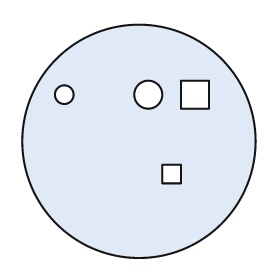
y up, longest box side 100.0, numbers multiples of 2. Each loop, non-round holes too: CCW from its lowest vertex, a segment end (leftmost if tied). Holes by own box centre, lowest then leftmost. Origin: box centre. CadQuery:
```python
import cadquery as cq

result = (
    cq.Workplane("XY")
    .moveTo(0.0, 0.0)
    .circle(50.0)
    .moveTo(10.0, -18.0)
    .lineTo(18.0, -18.0)
    .lineTo(18.0, -10.0)
    .lineTo(10.0, -10.0)
    .close()
    .moveTo(-32.0, 20.0)
    .circle(4.0)
    .moveTo(4.0, 20.0)
    .circle(6.0)
    .moveTo(18.0, 14.0)
    .lineTo(30.0, 14.0)
    .lineTo(30.0, 26.0)
    .lineTo(18.0, 26.0)
    .close()
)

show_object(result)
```